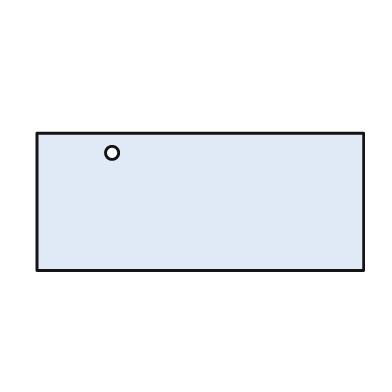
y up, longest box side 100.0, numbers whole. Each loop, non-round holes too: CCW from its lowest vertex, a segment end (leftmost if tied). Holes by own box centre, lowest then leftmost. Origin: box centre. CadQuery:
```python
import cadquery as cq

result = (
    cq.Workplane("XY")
    .moveTo(-50.0, -21.0)
    .lineTo(50.0, -21.0)
    .lineTo(50.0, 21.0)
    .lineTo(-50.0, 21.0)
    .close()
    .moveTo(-27.0, 15.0)
    .circle(2.0)
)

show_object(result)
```